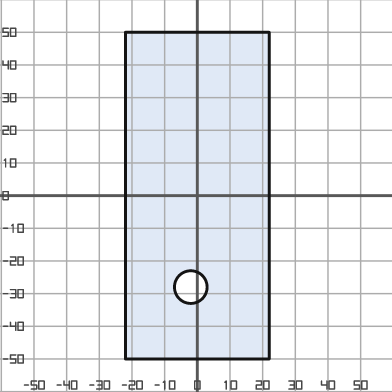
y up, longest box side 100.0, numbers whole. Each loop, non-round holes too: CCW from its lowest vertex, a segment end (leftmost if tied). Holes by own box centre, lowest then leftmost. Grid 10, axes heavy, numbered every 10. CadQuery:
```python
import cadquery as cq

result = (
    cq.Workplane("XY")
    .moveTo(-22.0, -50.0)
    .lineTo(22.0, -50.0)
    .lineTo(22.0, 50.0)
    .lineTo(-22.0, 50.0)
    .close()
    .moveTo(-2.0, -28.0)
    .circle(5.0)
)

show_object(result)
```